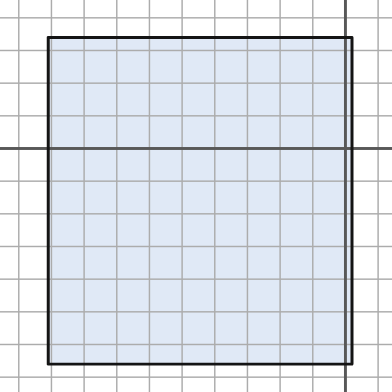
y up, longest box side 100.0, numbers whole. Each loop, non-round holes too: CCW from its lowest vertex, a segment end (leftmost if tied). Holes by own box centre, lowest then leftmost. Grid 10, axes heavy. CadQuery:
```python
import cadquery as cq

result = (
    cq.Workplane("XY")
    .moveTo(-91.0, -66.0)
    .lineTo(2.0, -66.0)
    .lineTo(2.0, 34.0)
    .lineTo(-91.0, 34.0)
    .close()
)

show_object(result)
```